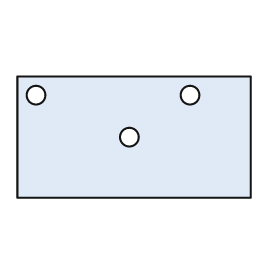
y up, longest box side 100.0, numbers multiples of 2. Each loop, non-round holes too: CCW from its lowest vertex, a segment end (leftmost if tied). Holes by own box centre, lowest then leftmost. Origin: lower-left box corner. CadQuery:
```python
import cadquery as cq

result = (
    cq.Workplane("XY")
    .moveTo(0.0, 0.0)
    .lineTo(100.0, 0.0)
    .lineTo(100.0, 52.0)
    .lineTo(0.0, 52.0)
    .close()
    .moveTo(48.0, 26.0)
    .circle(4.0)
    .moveTo(8.0, 44.0)
    .circle(4.0)
    .moveTo(74.0, 44.0)
    .circle(4.0)
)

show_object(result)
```